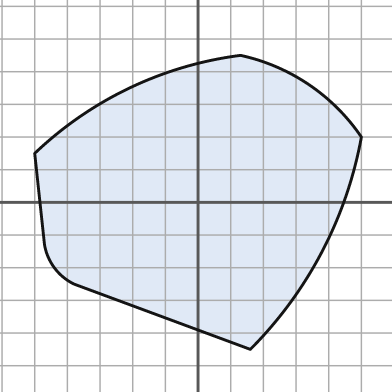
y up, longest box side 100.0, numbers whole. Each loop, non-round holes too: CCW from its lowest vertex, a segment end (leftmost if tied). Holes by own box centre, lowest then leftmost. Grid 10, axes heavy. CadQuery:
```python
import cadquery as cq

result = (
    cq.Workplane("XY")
    .moveTo(16.0, -45.0)
    .threePointArc((38.0, -15.0), (50.0, 20.0))
    .threePointArc((34.0, 36.0), (13.0, 45.0))
    .threePointArc((-21.0, 35.0), (-50.0, 15.0))
    .lineTo(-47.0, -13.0)
    .threePointArc((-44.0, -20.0), (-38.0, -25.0))
    .close()
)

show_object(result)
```